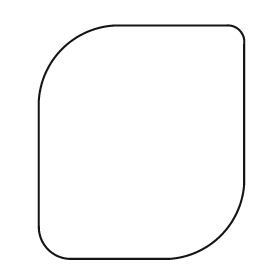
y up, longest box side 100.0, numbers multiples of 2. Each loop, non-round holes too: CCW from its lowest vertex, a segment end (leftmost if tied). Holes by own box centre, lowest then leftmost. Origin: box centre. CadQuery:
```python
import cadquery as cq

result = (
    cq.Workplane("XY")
    .moveTo(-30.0, -50.0)
    .lineTo(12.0, -50.0)
    .threePointArc((34.0, -40.0), (44.0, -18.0))
    .lineTo(44.0, 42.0)
    .threePointArc((42.0, 48.0), (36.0, 50.0))
    .lineTo(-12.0, 50.0)
    .threePointArc((-34.0, 40.0), (-44.0, 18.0))
    .lineTo(-44.0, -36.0)
    .threePointArc((-40.0, -46.0), (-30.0, -50.0))
    .close()
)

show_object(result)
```